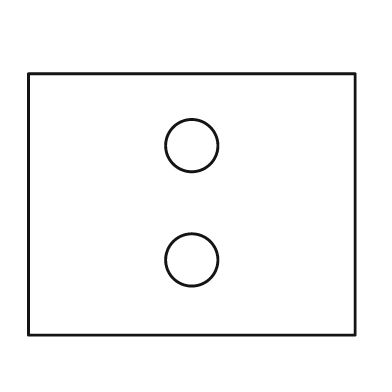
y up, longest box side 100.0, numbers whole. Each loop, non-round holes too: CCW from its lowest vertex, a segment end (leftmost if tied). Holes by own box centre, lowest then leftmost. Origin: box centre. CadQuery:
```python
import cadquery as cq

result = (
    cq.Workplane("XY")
    .moveTo(-50.0, -40.0)
    .lineTo(50.0, -40.0)
    .lineTo(50.0, 40.0)
    .lineTo(-50.0, 40.0)
    .close()
    .moveTo(0.0, -17.0)
    .circle(8.0)
    .moveTo(0.0, 18.0)
    .circle(8.0)
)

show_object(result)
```